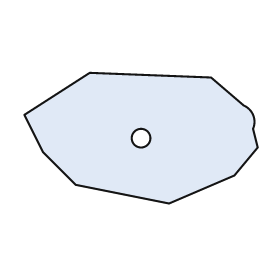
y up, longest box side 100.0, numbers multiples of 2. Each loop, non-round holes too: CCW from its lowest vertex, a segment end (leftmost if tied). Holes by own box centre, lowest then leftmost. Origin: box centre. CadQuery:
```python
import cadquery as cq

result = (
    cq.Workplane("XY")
    .moveTo(12.0, -28.0)
    .lineTo(40.0, -16.0)
    .lineTo(50.0, -4.0)
    .lineTo(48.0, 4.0)
    .threePointArc((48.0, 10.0), (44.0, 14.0))
    .lineTo(30.0, 26.0)
    .lineTo(-22.0, 28.0)
    .lineTo(-50.0, 10.0)
    .lineTo(-42.0, -6.0)
    .lineTo(-28.0, -20.0)
    .close()
    .moveTo(0.0, 0.0)
    .circle(4.0)
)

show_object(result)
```